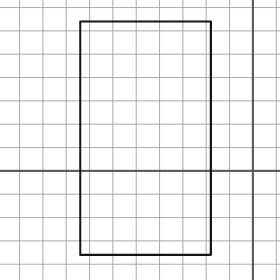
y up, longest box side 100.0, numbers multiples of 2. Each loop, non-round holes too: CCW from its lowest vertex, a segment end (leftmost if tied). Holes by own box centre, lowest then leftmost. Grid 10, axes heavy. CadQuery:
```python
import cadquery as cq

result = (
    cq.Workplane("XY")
    .moveTo(-74.0, -36.0)
    .lineTo(-18.0, -36.0)
    .lineTo(-18.0, 64.0)
    .lineTo(-74.0, 64.0)
    .close()
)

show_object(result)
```